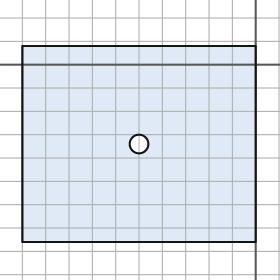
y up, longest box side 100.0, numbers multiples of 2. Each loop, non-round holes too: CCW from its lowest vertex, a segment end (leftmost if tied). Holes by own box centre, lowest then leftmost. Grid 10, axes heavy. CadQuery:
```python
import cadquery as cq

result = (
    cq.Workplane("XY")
    .moveTo(-100.0, -76.0)
    .lineTo(0.0, -76.0)
    .lineTo(0.0, 8.0)
    .lineTo(-100.0, 8.0)
    .close()
    .moveTo(-50.0, -34.0)
    .circle(4.0)
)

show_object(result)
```